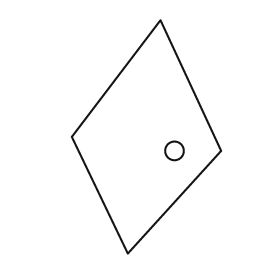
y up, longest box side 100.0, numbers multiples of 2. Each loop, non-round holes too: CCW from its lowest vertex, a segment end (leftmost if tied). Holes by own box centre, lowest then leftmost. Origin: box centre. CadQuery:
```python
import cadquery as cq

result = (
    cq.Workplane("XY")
    .moveTo(-8.0, -50.0)
    .lineTo(32.0, -6.0)
    .lineTo(6.0, 50.0)
    .lineTo(-32.0, 0.0)
    .close()
    .moveTo(12.0, -6.0)
    .circle(4.0)
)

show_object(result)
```